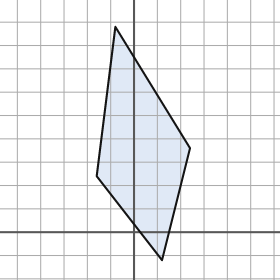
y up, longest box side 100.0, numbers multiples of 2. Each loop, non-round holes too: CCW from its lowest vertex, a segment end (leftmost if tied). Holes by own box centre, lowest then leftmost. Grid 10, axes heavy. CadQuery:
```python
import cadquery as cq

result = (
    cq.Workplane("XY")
    .moveTo(12.0, -12.0)
    .lineTo(24.0, 36.0)
    .lineTo(-8.0, 88.0)
    .lineTo(-16.0, 24.0)
    .close()
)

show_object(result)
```